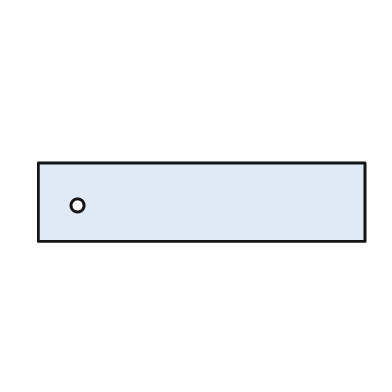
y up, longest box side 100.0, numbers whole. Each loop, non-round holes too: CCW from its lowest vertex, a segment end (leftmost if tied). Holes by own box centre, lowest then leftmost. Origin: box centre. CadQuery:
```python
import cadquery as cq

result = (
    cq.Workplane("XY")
    .moveTo(-50.0, -12.0)
    .lineTo(50.0, -12.0)
    .lineTo(50.0, 12.0)
    .lineTo(-50.0, 12.0)
    .close()
    .moveTo(-38.0, -1.0)
    .circle(2.0)
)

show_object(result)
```